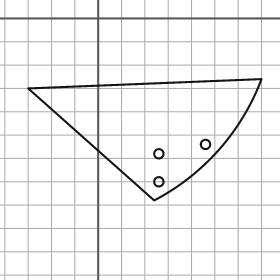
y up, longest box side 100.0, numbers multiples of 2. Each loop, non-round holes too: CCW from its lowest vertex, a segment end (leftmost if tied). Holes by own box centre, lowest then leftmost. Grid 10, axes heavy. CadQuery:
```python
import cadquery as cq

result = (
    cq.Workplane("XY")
    .moveTo(24.0, -78.0)
    .threePointArc((52.0, -56.0), (70.0, -26.0))
    .lineTo(-30.0, -30.0)
    .close()
    .moveTo(26.0, -70.0)
    .circle(2.0)
    .moveTo(26.0, -58.0)
    .circle(2.0)
    .moveTo(46.0, -54.0)
    .circle(2.0)
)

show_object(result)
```